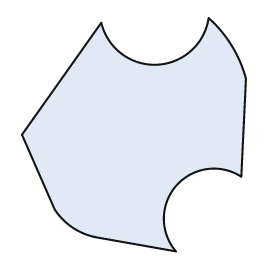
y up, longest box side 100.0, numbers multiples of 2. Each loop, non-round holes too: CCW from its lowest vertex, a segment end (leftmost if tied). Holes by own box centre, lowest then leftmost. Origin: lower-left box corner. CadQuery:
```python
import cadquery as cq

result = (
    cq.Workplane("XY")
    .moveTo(66.0, 0.0)
    .threePointArc((66.0, 28.0), (94.0, 32.0))
    .lineTo(96.0, 74.0)
    .threePointArc((90.0, 88.0), (80.0, 100.0))
    .threePointArc((58.0, 80.0), (34.0, 98.0))
    .lineTo(0.0, 50.0)
    .lineTo(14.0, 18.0)
    .threePointArc((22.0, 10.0), (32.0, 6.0))
    .close()
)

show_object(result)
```